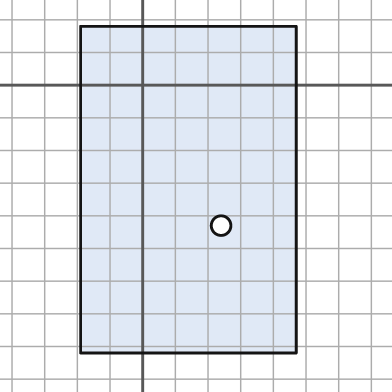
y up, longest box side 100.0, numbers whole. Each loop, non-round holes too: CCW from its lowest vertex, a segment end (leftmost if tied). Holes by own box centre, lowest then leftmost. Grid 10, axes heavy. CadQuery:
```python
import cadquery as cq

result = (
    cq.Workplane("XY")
    .moveTo(-19.0, -82.0)
    .lineTo(47.0, -82.0)
    .lineTo(47.0, 18.0)
    .lineTo(-19.0, 18.0)
    .close()
    .moveTo(24.0, -43.0)
    .circle(3.0)
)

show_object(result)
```